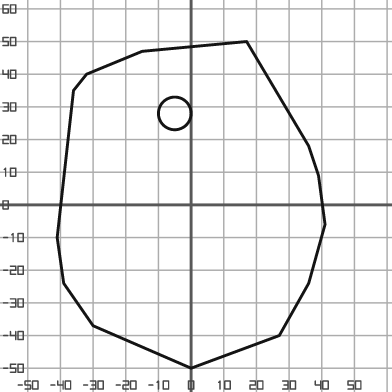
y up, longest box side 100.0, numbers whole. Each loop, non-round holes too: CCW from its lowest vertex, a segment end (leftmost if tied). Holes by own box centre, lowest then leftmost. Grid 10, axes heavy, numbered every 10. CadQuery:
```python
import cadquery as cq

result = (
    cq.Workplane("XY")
    .moveTo(0.0, -50.0)
    .lineTo(27.0, -40.0)
    .lineTo(36.0, -24.0)
    .lineTo(41.0, -6.0)
    .lineTo(39.0, 9.0)
    .lineTo(36.0, 18.0)
    .lineTo(17.0, 50.0)
    .lineTo(-15.0, 47.0)
    .lineTo(-32.0, 40.0)
    .lineTo(-36.0, 35.0)
    .lineTo(-41.0, -10.0)
    .lineTo(-39.0, -24.0)
    .lineTo(-30.0, -37.0)
    .close()
    .moveTo(-5.0, 28.0)
    .circle(5.0)
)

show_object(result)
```